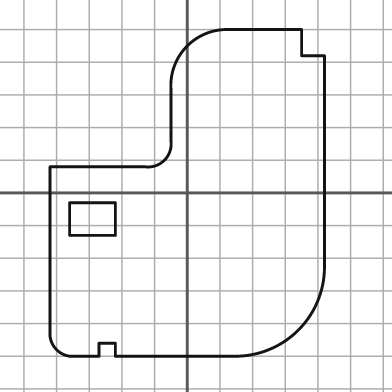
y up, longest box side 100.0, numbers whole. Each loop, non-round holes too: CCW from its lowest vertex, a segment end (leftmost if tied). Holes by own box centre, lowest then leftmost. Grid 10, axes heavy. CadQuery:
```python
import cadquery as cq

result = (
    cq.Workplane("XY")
    .moveTo(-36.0, -50.0)
    .lineTo(-27.0, -50.0)
    .lineTo(-27.0, -46.0)
    .lineTo(-22.0, -46.0)
    .lineTo(-22.0, -50.0)
    .lineTo(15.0, -50.0)
    .threePointArc((34.0, -42.0), (42.0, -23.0))
    .lineTo(42.0, 42.0)
    .lineTo(35.0, 42.0)
    .lineTo(35.0, 50.0)
    .lineTo(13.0, 50.0)
    .threePointArc((0.0, 45.0), (-5.0, 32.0))
    .lineTo(-5.0, 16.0)
    .threePointArc((-7.0, 10.0), (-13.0, 8.0))
    .lineTo(-42.0, 8.0)
    .lineTo(-42.0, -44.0)
    .threePointArc((-40.0, -48.0), (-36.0, -50.0))
    .close()
    .moveTo(-36.0, -13.0)
    .lineTo(-22.0, -13.0)
    .lineTo(-22.0, -3.0)
    .lineTo(-36.0, -3.0)
    .close()
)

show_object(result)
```